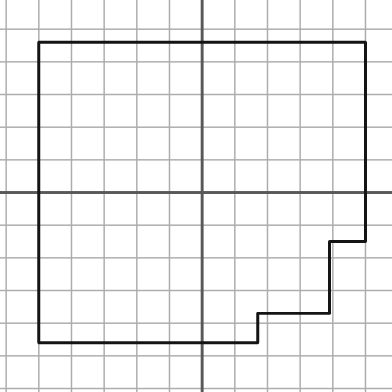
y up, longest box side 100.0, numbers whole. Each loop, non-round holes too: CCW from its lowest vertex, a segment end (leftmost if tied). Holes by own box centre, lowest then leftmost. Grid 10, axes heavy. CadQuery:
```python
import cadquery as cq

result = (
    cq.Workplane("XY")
    .moveTo(-50.0, -46.0)
    .lineTo(17.0, -46.0)
    .lineTo(17.0, -37.0)
    .lineTo(39.0, -37.0)
    .lineTo(39.0, -15.0)
    .lineTo(50.0, -15.0)
    .lineTo(50.0, 46.0)
    .lineTo(-50.0, 46.0)
    .close()
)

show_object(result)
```